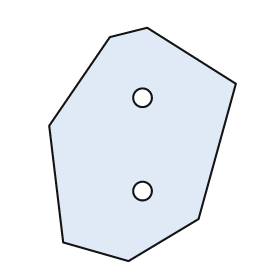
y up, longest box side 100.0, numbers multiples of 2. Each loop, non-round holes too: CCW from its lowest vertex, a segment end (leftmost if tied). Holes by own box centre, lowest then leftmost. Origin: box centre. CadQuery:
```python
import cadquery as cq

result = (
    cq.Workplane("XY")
    .moveTo(-6.0, -50.0)
    .lineTo(24.0, -32.0)
    .lineTo(40.0, 26.0)
    .lineTo(2.0, 50.0)
    .lineTo(-14.0, 46.0)
    .lineTo(-40.0, 8.0)
    .lineTo(-34.0, -42.0)
    .close()
    .moveTo(0.0, -20.0)
    .circle(4.0)
    .moveTo(0.0, 20.0)
    .circle(4.0)
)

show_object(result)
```